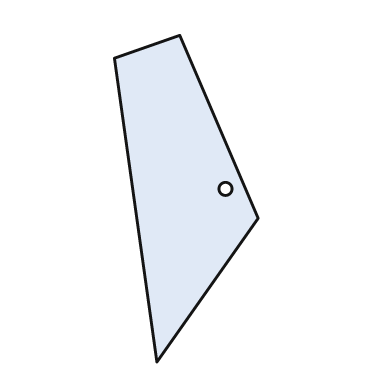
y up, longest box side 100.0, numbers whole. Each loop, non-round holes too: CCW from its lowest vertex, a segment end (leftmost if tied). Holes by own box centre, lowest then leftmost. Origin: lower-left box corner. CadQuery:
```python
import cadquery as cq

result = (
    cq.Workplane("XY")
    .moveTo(13.0, 0.0)
    .lineTo(44.0, 44.0)
    .lineTo(20.0, 100.0)
    .lineTo(0.0, 93.0)
    .close()
    .moveTo(34.0, 53.0)
    .circle(2.0)
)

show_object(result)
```